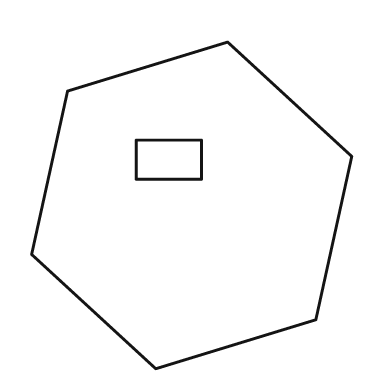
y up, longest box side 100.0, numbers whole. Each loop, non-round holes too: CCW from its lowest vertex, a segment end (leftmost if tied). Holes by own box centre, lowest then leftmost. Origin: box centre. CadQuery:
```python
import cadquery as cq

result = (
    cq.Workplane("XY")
    .moveTo(-11.0, -50.0)
    .lineTo(38.0, -35.0)
    .lineTo(49.0, 15.0)
    .lineTo(11.0, 50.0)
    .lineTo(-38.0, 35.0)
    .lineTo(-49.0, -15.0)
    .close()
    .moveTo(-17.0, 8.0)
    .lineTo(3.0, 8.0)
    .lineTo(3.0, 20.0)
    .lineTo(-17.0, 20.0)
    .close()
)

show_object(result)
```